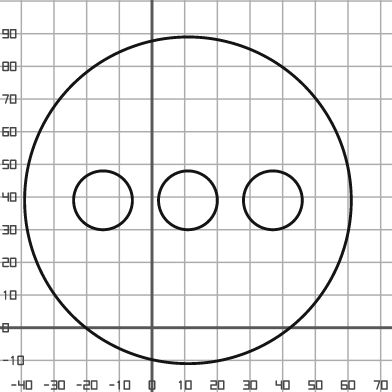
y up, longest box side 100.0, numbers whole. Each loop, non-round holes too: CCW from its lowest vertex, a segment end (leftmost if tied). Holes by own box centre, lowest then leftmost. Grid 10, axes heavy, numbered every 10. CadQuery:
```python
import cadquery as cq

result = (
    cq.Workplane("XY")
    .moveTo(11.0, 39.0)
    .circle(50.0)
    .moveTo(-15.0, 39.0)
    .circle(9.0)
    .moveTo(11.0, 39.0)
    .circle(9.0)
    .moveTo(37.0, 39.0)
    .circle(9.0)
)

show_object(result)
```